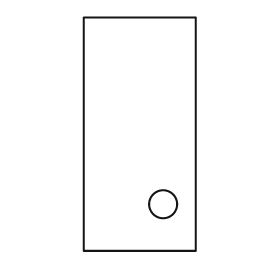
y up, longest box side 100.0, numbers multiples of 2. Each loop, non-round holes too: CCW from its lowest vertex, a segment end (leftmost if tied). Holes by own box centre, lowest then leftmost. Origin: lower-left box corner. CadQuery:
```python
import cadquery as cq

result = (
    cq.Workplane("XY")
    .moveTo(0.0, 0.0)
    .lineTo(48.0, 0.0)
    .lineTo(48.0, 100.0)
    .lineTo(0.0, 100.0)
    .close()
    .moveTo(34.0, 20.0)
    .circle(6.0)
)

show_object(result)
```